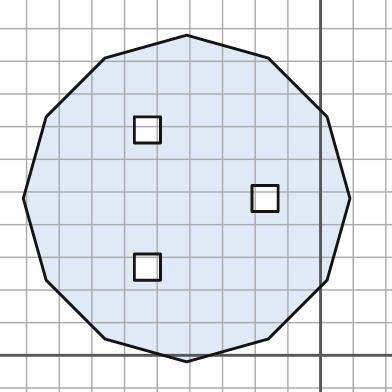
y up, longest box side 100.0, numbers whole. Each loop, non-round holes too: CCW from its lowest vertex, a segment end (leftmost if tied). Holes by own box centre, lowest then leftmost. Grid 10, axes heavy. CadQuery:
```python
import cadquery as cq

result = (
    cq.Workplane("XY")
    .moveTo(-41.0, -2.0)
    .lineTo(-16.0, 5.0)
    .lineTo(2.0, 23.0)
    .lineTo(9.0, 48.0)
    .lineTo(2.0, 73.0)
    .lineTo(-16.0, 91.0)
    .lineTo(-41.0, 98.0)
    .lineTo(-66.0, 91.0)
    .lineTo(-84.0, 73.0)
    .lineTo(-91.0, 48.0)
    .lineTo(-84.0, 23.0)
    .lineTo(-66.0, 5.0)
    .close()
    .moveTo(-57.0, 23.0)
    .lineTo(-49.0, 23.0)
    .lineTo(-49.0, 31.0)
    .lineTo(-57.0, 31.0)
    .close()
    .moveTo(-21.0, 44.0)
    .lineTo(-13.0, 44.0)
    .lineTo(-13.0, 52.0)
    .lineTo(-21.0, 52.0)
    .close()
    .moveTo(-57.0, 65.0)
    .lineTo(-49.0, 65.0)
    .lineTo(-49.0, 73.0)
    .lineTo(-57.0, 73.0)
    .close()
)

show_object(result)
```